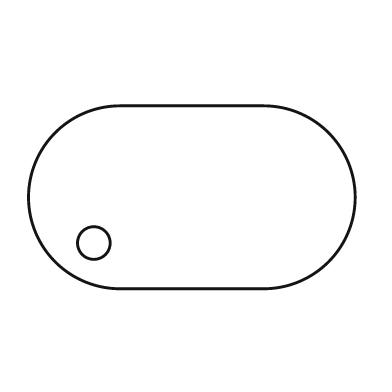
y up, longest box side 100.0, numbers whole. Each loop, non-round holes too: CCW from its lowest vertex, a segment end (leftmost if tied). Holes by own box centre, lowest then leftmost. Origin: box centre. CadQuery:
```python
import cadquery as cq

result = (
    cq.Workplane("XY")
    .moveTo(-22.0, -28.0)
    .lineTo(22.0, -28.0)
    .threePointArc((50.0, 0.0), (22.0, 28.0))
    .lineTo(-22.0, 28.0)
    .threePointArc((-50.0, 0.0), (-22.0, -28.0))
    .close()
    .moveTo(-30.0, -14.0)
    .circle(5.0)
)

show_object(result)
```